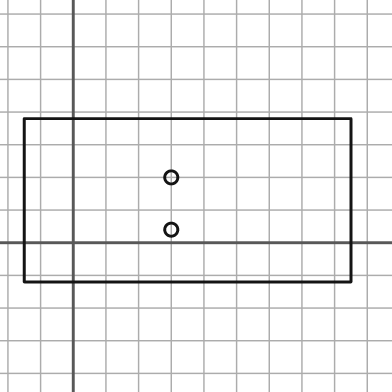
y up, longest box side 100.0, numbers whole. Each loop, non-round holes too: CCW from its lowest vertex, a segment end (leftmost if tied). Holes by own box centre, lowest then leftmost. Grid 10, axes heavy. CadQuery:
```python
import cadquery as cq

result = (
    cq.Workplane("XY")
    .moveTo(-15.0, -12.0)
    .lineTo(85.0, -12.0)
    .lineTo(85.0, 38.0)
    .lineTo(-15.0, 38.0)
    .close()
    .moveTo(30.0, 4.0)
    .circle(2.0)
    .moveTo(30.0, 20.0)
    .circle(2.0)
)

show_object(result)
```